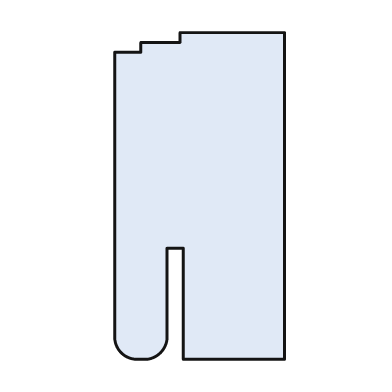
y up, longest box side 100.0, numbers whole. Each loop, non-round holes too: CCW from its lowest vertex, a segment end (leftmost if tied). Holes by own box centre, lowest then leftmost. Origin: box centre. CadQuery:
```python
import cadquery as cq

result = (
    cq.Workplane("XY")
    .moveTo(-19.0, -50.0)
    .lineTo(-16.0, -50.0)
    .threePointArc((-12.0, -48.0), (-10.0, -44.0))
    .lineTo(-10.0, -16.0)
    .lineTo(-5.0, -16.0)
    .lineTo(-5.0, -50.0)
    .lineTo(26.0, -50.0)
    .lineTo(26.0, 50.0)
    .lineTo(-6.0, 50.0)
    .lineTo(-6.0, 47.0)
    .lineTo(-18.0, 47.0)
    .lineTo(-18.0, 44.0)
    .lineTo(-26.0, 44.0)
    .lineTo(-26.0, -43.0)
    .threePointArc((-24.0, -48.0), (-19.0, -50.0))
    .close()
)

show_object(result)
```